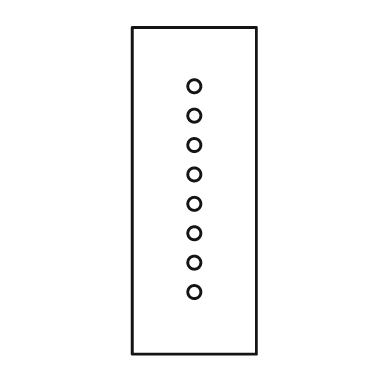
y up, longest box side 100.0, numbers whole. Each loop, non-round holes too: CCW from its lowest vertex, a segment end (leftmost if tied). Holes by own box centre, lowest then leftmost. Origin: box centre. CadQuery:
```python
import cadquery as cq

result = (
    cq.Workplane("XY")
    .moveTo(-19.0, -50.0)
    .lineTo(19.0, -50.0)
    .lineTo(19.0, 50.0)
    .lineTo(-19.0, 50.0)
    .close()
    .moveTo(0.0, -31.0)
    .circle(2.0)
    .moveTo(0.0, -22.0)
    .circle(2.0)
    .moveTo(0.0, -13.0)
    .circle(2.0)
    .moveTo(0.0, -4.0)
    .circle(2.0)
    .moveTo(0.0, 5.0)
    .circle(2.0)
    .moveTo(0.0, 14.0)
    .circle(2.0)
    .moveTo(0.0, 23.0)
    .circle(2.0)
    .moveTo(0.0, 32.0)
    .circle(2.0)
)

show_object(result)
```